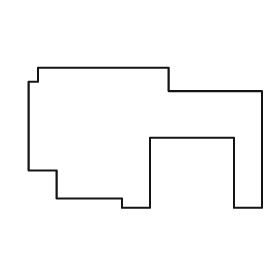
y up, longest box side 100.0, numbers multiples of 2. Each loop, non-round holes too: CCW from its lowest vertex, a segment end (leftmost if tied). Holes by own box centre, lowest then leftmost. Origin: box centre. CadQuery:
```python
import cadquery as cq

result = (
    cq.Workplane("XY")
    .moveTo(-10.0, -30.0)
    .lineTo(2.0, -30.0)
    .lineTo(2.0, 0.0)
    .lineTo(38.0, 0.0)
    .lineTo(38.0, -30.0)
    .lineTo(50.0, -30.0)
    .lineTo(50.0, 20.0)
    .lineTo(10.0, 20.0)
    .lineTo(10.0, 30.0)
    .lineTo(-46.0, 30.0)
    .lineTo(-46.0, 24.0)
    .lineTo(-50.0, 24.0)
    .lineTo(-50.0, -14.0)
    .lineTo(-38.0, -14.0)
    .lineTo(-38.0, -26.0)
    .lineTo(-10.0, -26.0)
    .close()
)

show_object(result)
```